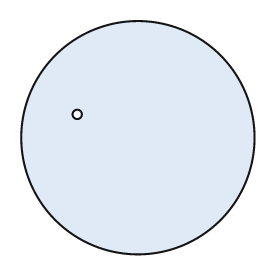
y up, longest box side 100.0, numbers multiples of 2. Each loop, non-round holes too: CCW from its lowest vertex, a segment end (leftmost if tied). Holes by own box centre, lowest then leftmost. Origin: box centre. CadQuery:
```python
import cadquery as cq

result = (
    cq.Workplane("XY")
    .moveTo(0.0, 0.0)
    .circle(50.0)
    .moveTo(-26.0, 10.0)
    .circle(2.0)
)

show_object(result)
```